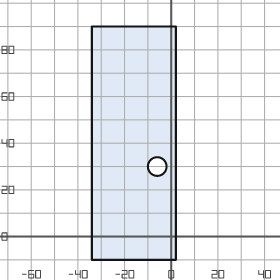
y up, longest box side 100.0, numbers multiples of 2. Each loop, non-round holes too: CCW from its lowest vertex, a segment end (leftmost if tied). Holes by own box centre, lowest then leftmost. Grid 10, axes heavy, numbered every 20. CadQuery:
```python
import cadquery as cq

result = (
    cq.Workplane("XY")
    .moveTo(-34.0, -10.0)
    .lineTo(2.0, -10.0)
    .lineTo(2.0, 90.0)
    .lineTo(-34.0, 90.0)
    .close()
    .moveTo(-6.0, 30.0)
    .circle(4.0)
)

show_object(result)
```